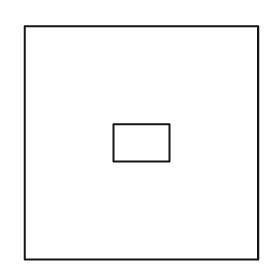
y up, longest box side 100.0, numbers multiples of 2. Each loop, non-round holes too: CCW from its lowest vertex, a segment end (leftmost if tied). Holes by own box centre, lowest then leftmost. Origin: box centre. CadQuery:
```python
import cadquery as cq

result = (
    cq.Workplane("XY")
    .moveTo(-50.0, -50.0)
    .lineTo(50.0, -50.0)
    .lineTo(50.0, 50.0)
    .lineTo(-50.0, 50.0)
    .close()
    .moveTo(-12.0, -8.0)
    .lineTo(12.0, -8.0)
    .lineTo(12.0, 8.0)
    .lineTo(-12.0, 8.0)
    .close()
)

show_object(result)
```